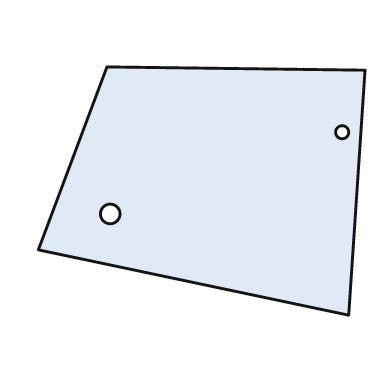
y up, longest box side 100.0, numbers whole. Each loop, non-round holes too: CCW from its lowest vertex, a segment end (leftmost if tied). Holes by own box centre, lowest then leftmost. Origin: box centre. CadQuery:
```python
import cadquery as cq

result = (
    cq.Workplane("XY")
    .moveTo(45.0, -38.0)
    .lineTo(50.0, 37.0)
    .lineTo(-29.0, 38.0)
    .lineTo(-50.0, -18.0)
    .close()
    .moveTo(-28.0, -7.0)
    .circle(3.0)
    .moveTo(43.0, 18.0)
    .circle(2.0)
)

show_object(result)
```